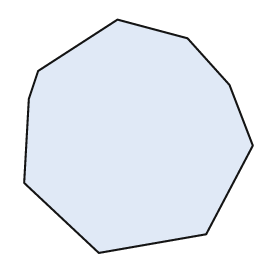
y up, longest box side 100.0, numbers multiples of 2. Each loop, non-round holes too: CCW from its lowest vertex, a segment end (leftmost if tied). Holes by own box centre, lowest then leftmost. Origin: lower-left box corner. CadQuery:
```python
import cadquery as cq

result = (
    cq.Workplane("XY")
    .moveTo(32.0, 0.0)
    .lineTo(78.0, 8.0)
    .lineTo(98.0, 46.0)
    .lineTo(88.0, 72.0)
    .lineTo(70.0, 92.0)
    .lineTo(40.0, 100.0)
    .lineTo(6.0, 78.0)
    .lineTo(2.0, 66.0)
    .lineTo(0.0, 30.0)
    .close()
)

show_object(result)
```